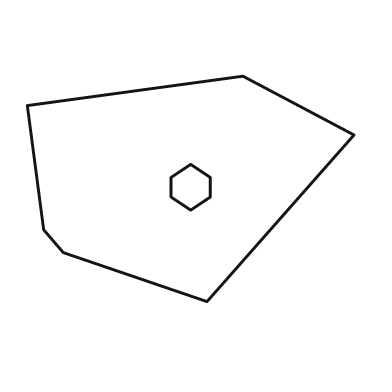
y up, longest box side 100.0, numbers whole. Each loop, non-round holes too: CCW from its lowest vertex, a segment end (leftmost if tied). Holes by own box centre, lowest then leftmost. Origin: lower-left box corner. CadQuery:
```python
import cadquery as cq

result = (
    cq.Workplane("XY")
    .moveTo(55.0, 0.0)
    .lineTo(100.0, 51.0)
    .lineTo(66.0, 69.0)
    .lineTo(0.0, 60.0)
    .lineTo(5.0, 22.0)
    .lineTo(11.0, 15.0)
    .close()
    .moveTo(50.0, 28.0)
    .lineTo(56.0, 32.0)
    .lineTo(56.0, 38.0)
    .lineTo(50.0, 42.0)
    .lineTo(44.0, 38.0)
    .lineTo(44.0, 32.0)
    .close()
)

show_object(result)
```